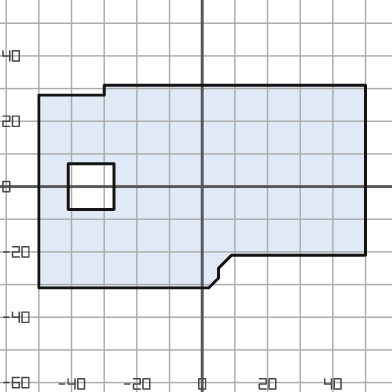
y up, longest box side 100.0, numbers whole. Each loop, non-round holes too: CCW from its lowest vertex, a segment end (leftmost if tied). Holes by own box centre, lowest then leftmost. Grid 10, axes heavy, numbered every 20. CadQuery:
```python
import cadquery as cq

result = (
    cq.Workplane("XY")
    .moveTo(-50.0, -31.0)
    .lineTo(2.0, -31.0)
    .lineTo(5.0, -28.0)
    .lineTo(5.0, -25.0)
    .lineTo(9.0, -21.0)
    .lineTo(50.0, -21.0)
    .lineTo(50.0, 31.0)
    .lineTo(-30.0, 31.0)
    .lineTo(-30.0, 28.0)
    .lineTo(-50.0, 28.0)
    .close()
    .moveTo(-41.0, -7.0)
    .lineTo(-27.0, -7.0)
    .lineTo(-27.0, 7.0)
    .lineTo(-41.0, 7.0)
    .close()
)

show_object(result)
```